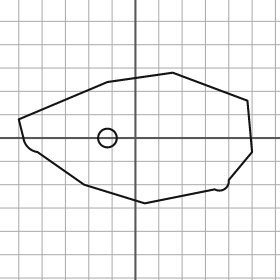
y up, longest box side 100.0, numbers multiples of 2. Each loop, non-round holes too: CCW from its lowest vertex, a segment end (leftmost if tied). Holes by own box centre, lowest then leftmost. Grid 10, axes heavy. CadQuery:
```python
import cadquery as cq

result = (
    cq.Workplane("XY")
    .moveTo(4.0, -28.0)
    .lineTo(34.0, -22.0)
    .threePointArc((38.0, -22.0), (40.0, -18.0))
    .lineTo(50.0, -6.0)
    .lineTo(48.0, 16.0)
    .lineTo(16.0, 28.0)
    .lineTo(-12.0, 24.0)
    .lineTo(-50.0, 8.0)
    .lineTo(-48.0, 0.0)
    .threePointArc((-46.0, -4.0), (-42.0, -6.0))
    .lineTo(-22.0, -20.0)
    .close()
    .moveTo(-12.0, 0.0)
    .circle(4.0)
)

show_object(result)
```